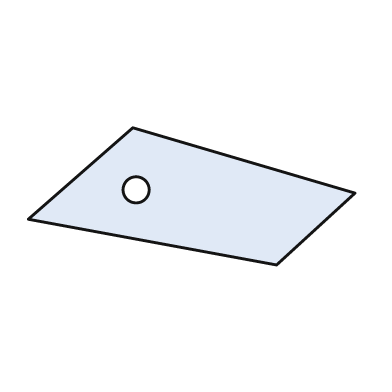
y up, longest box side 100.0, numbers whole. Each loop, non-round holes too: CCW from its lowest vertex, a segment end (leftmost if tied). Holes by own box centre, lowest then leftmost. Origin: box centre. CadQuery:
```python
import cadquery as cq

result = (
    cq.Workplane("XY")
    .moveTo(26.0, -21.0)
    .lineTo(50.0, 1.0)
    .lineTo(-18.0, 21.0)
    .lineTo(-50.0, -7.0)
    .close()
    .moveTo(-17.0, 2.0)
    .circle(4.0)
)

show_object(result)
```